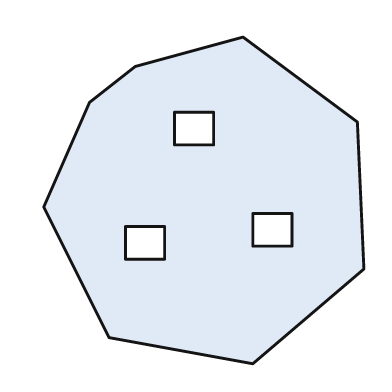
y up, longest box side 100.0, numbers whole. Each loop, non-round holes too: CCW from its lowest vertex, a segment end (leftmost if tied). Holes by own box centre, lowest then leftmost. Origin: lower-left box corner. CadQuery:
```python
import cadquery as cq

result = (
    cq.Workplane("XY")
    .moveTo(64.0, 0.0)
    .lineTo(98.0, 29.0)
    .lineTo(96.0, 74.0)
    .lineTo(61.0, 100.0)
    .lineTo(28.0, 91.0)
    .lineTo(14.0, 80.0)
    .lineTo(0.0, 48.0)
    .lineTo(20.0, 8.0)
    .close()
    .moveTo(25.0, 32.0)
    .lineTo(37.0, 32.0)
    .lineTo(37.0, 42.0)
    .lineTo(25.0, 42.0)
    .close()
    .moveTo(64.0, 36.0)
    .lineTo(76.0, 36.0)
    .lineTo(76.0, 46.0)
    .lineTo(64.0, 46.0)
    .close()
    .moveTo(40.0, 67.0)
    .lineTo(52.0, 67.0)
    .lineTo(52.0, 77.0)
    .lineTo(40.0, 77.0)
    .close()
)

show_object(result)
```